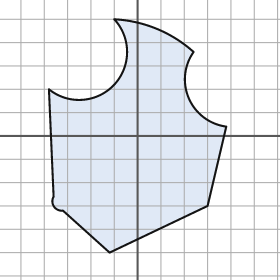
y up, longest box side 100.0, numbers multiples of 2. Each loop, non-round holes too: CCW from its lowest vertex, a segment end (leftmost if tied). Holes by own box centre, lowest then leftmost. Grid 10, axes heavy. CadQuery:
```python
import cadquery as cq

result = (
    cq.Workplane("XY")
    .moveTo(-12.0, -50.0)
    .lineTo(30.0, -30.0)
    .lineTo(38.0, 4.0)
    .threePointArc((22.0, 16.0), (24.0, 36.0))
    .threePointArc((8.0, 46.0), (-10.0, 50.0))
    .threePointArc((-10.0, 22.0), (-38.0, 20.0))
    .lineTo(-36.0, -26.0)
    .threePointArc((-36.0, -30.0), (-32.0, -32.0))
    .close()
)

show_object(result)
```